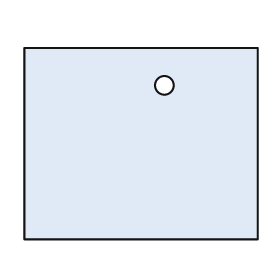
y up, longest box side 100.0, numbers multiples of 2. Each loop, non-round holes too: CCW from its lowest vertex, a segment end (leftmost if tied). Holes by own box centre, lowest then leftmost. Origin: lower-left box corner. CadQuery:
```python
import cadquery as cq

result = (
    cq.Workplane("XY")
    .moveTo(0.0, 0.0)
    .lineTo(100.0, 0.0)
    .lineTo(100.0, 82.0)
    .lineTo(0.0, 82.0)
    .close()
    .moveTo(60.0, 66.0)
    .circle(4.0)
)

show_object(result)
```